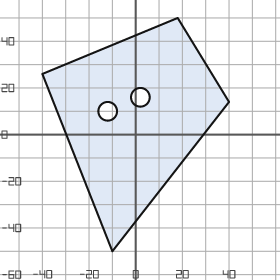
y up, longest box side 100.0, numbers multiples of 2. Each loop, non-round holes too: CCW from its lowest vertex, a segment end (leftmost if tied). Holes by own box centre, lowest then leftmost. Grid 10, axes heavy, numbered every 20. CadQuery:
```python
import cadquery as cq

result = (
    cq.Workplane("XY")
    .moveTo(-10.0, -50.0)
    .lineTo(40.0, 14.0)
    .lineTo(18.0, 50.0)
    .lineTo(-40.0, 26.0)
    .close()
    .moveTo(-12.0, 10.0)
    .circle(4.0)
    .moveTo(2.0, 16.0)
    .circle(4.0)
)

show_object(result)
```